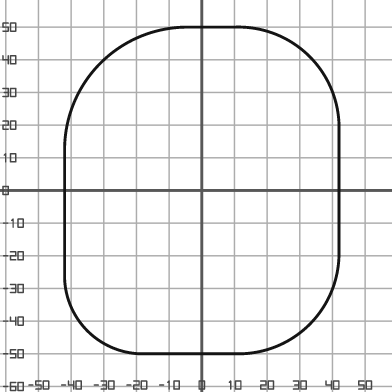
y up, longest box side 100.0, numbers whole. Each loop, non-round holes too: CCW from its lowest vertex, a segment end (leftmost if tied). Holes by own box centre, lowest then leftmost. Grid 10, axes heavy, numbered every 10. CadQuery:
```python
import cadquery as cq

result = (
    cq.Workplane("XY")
    .moveTo(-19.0, -50.0)
    .lineTo(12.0, -50.0)
    .threePointArc((33.0, -41.0), (42.0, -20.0))
    .lineTo(42.0, 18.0)
    .threePointArc((33.0, 41.0), (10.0, 50.0))
    .lineTo(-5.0, 50.0)
    .threePointArc((-31.0, 39.0), (-42.0, 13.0))
    .lineTo(-42.0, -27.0)
    .threePointArc((-35.0, -43.0), (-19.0, -50.0))
    .close()
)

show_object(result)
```